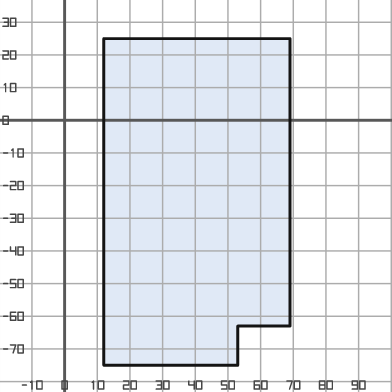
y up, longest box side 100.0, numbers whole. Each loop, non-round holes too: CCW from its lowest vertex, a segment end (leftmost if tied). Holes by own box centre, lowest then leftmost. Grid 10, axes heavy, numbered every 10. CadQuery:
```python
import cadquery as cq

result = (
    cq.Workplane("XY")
    .moveTo(12.0, -75.0)
    .lineTo(53.0, -75.0)
    .lineTo(53.0, -63.0)
    .lineTo(69.0, -63.0)
    .lineTo(69.0, 25.0)
    .lineTo(12.0, 25.0)
    .close()
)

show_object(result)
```